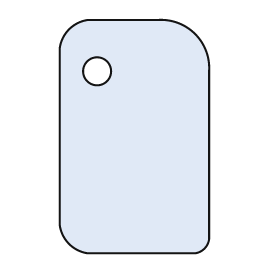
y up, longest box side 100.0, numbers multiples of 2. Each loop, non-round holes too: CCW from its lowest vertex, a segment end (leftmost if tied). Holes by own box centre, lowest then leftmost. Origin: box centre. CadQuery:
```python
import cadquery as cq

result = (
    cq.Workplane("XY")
    .moveTo(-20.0, -50.0)
    .lineTo(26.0, -50.0)
    .threePointArc((30.0, -48.0), (32.0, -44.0))
    .lineTo(32.0, 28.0)
    .threePointArc((26.0, 44.0), (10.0, 50.0))
    .lineTo(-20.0, 50.0)
    .threePointArc((-28.0, 46.0), (-32.0, 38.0))
    .lineTo(-32.0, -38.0)
    .threePointArc((-28.0, -46.0), (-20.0, -50.0))
    .close()
    .moveTo(-16.0, 28.0)
    .circle(6.0)
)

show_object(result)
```